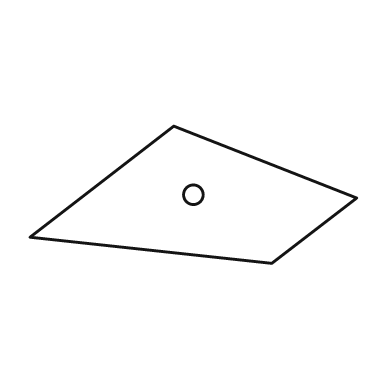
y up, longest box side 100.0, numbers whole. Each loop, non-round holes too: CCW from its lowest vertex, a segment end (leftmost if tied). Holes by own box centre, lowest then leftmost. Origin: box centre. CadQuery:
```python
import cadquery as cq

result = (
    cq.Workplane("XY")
    .moveTo(24.0, -21.0)
    .lineTo(50.0, -1.0)
    .lineTo(-6.0, 21.0)
    .lineTo(-50.0, -13.0)
    .close()
    .moveTo(0.0, 0.0)
    .circle(3.0)
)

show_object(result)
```